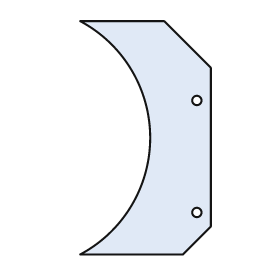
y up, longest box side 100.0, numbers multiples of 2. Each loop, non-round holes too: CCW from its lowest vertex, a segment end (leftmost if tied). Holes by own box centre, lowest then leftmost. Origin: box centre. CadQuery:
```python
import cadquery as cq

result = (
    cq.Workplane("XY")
    .moveTo(-28.0, -50.0)
    .lineTo(16.0, -50.0)
    .lineTo(28.0, -38.0)
    .lineTo(28.0, 30.0)
    .lineTo(8.0, 50.0)
    .lineTo(-28.0, 50.0)
    .threePointArc((2.0, 0.0), (-28.0, -50.0))
    .close()
    .moveTo(22.0, -32.0)
    .circle(2.0)
    .moveTo(22.0, 16.0)
    .circle(2.0)
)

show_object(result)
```